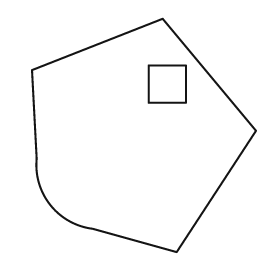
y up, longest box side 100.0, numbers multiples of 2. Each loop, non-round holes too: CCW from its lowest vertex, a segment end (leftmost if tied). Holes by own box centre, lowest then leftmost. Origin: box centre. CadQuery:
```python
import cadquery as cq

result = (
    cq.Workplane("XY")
    .moveTo(14.0, -50.0)
    .lineTo(48.0, 2.0)
    .lineTo(8.0, 50.0)
    .lineTo(-48.0, 28.0)
    .lineTo(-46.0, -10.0)
    .threePointArc((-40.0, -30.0), (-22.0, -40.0))
    .close()
    .moveTo(2.0, 14.0)
    .lineTo(18.0, 14.0)
    .lineTo(18.0, 30.0)
    .lineTo(2.0, 30.0)
    .close()
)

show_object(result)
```